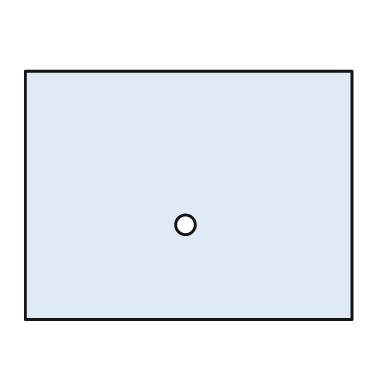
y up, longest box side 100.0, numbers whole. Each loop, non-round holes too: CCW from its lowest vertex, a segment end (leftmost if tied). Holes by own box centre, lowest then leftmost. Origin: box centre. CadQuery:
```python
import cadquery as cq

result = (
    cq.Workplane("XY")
    .moveTo(-50.0, -38.0)
    .lineTo(50.0, -38.0)
    .lineTo(50.0, 38.0)
    .lineTo(-50.0, 38.0)
    .close()
    .moveTo(-1.0, -9.0)
    .circle(3.0)
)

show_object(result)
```